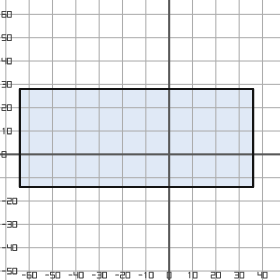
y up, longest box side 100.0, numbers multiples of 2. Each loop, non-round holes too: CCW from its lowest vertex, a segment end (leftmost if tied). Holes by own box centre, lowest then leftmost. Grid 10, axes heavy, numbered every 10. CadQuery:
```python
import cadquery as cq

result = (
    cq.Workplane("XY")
    .moveTo(-64.0, -14.0)
    .lineTo(36.0, -14.0)
    .lineTo(36.0, 28.0)
    .lineTo(-64.0, 28.0)
    .close()
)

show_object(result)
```